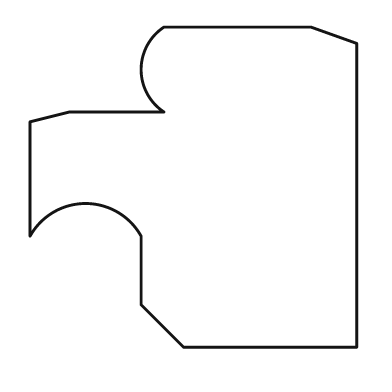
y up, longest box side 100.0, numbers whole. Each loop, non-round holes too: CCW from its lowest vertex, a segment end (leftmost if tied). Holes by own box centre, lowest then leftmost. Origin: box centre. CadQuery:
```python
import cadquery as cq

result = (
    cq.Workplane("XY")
    .moveTo(-3.0, -49.0)
    .lineTo(50.0, -49.0)
    .lineTo(50.0, 44.0)
    .lineTo(36.0, 49.0)
    .lineTo(-9.0, 49.0)
    .threePointArc((-16.0, 36.0), (-9.0, 23.0))
    .lineTo(-38.0, 23.0)
    .lineTo(-50.0, 20.0)
    .lineTo(-50.0, -15.0)
    .threePointArc((-33.0, -5.0), (-16.0, -15.0))
    .lineTo(-16.0, -36.0)
    .close()
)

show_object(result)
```